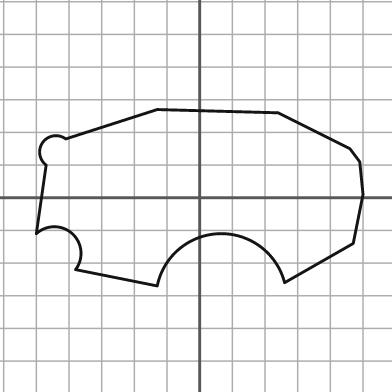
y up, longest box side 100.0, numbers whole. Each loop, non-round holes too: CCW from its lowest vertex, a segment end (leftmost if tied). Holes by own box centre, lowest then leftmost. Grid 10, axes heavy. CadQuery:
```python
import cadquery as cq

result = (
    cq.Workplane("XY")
    .moveTo(-13.0, -27.0)
    .threePointArc((6.0, -11.0), (26.0, -26.0))
    .lineTo(47.0, -14.0)
    .lineTo(50.0, 1.0)
    .lineTo(49.0, 11.0)
    .lineTo(46.0, 15.0)
    .lineTo(24.0, 26.0)
    .lineTo(-13.0, 27.0)
    .lineTo(-41.0, 18.0)
    .threePointArc((-48.0, 17.0), (-47.0, 10.0))
    .lineTo(-50.0, -11.0)
    .threePointArc((-39.0, -11.0), (-38.0, -22.0))
    .close()
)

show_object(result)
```